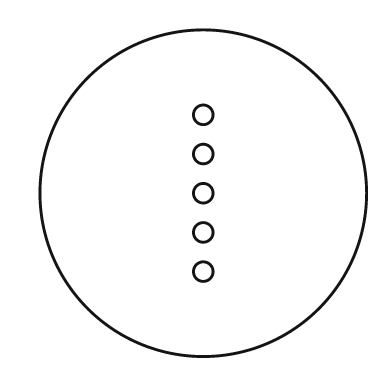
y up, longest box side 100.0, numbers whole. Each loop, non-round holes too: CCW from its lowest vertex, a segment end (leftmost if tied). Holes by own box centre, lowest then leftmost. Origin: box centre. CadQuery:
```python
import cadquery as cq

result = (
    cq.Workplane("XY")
    .moveTo(0.0, 0.0)
    .circle(50.0)
    .moveTo(0.0, -24.0)
    .circle(3.0)
    .moveTo(0.0, -12.0)
    .circle(3.0)
    .moveTo(0.0, 0.0)
    .circle(3.0)
    .moveTo(0.0, 12.0)
    .circle(3.0)
    .moveTo(0.0, 24.0)
    .circle(3.0)
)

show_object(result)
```